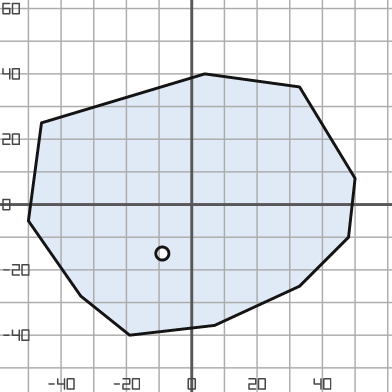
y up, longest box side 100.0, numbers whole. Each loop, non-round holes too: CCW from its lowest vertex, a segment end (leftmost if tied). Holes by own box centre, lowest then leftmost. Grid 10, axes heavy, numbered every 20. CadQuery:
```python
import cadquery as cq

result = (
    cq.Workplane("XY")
    .moveTo(-19.0, -40.0)
    .lineTo(7.0, -37.0)
    .lineTo(33.0, -25.0)
    .lineTo(48.0, -10.0)
    .lineTo(50.0, 8.0)
    .lineTo(33.0, 36.0)
    .lineTo(4.0, 40.0)
    .lineTo(-46.0, 25.0)
    .lineTo(-50.0, -5.0)
    .lineTo(-34.0, -28.0)
    .close()
    .moveTo(-9.0, -15.0)
    .circle(2.0)
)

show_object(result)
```